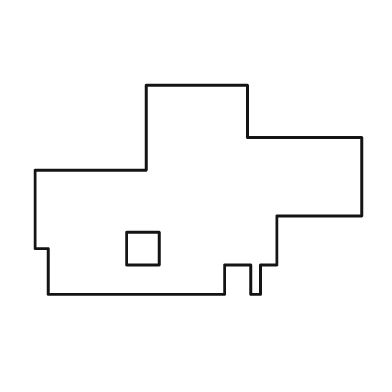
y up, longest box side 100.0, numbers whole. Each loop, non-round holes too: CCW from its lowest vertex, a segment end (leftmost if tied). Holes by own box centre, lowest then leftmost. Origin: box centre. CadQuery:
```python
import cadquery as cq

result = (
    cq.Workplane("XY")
    .moveTo(-46.0, -32.0)
    .lineTo(8.0, -32.0)
    .lineTo(8.0, -23.0)
    .lineTo(16.0, -23.0)
    .lineTo(16.0, -32.0)
    .lineTo(19.0, -32.0)
    .lineTo(19.0, -23.0)
    .lineTo(24.0, -23.0)
    .lineTo(24.0, -8.0)
    .lineTo(50.0, -8.0)
    .lineTo(50.0, 16.0)
    .lineTo(15.0, 16.0)
    .lineTo(15.0, 32.0)
    .lineTo(-16.0, 32.0)
    .lineTo(-16.0, 6.0)
    .lineTo(-50.0, 6.0)
    .lineTo(-50.0, -18.0)
    .lineTo(-46.0, -18.0)
    .close()
    .moveTo(-22.0, -23.0)
    .lineTo(-12.0, -23.0)
    .lineTo(-12.0, -13.0)
    .lineTo(-22.0, -13.0)
    .close()
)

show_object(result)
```